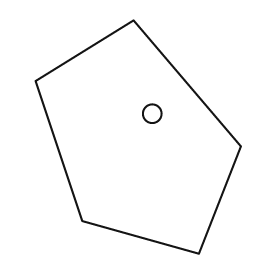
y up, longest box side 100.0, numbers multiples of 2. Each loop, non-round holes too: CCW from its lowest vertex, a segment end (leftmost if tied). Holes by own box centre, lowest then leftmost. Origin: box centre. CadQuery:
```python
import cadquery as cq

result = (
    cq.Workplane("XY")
    .moveTo(26.0, -50.0)
    .lineTo(44.0, -4.0)
    .lineTo(-2.0, 50.0)
    .lineTo(-44.0, 24.0)
    .lineTo(-24.0, -36.0)
    .close()
    .moveTo(6.0, 10.0)
    .circle(4.0)
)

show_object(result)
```